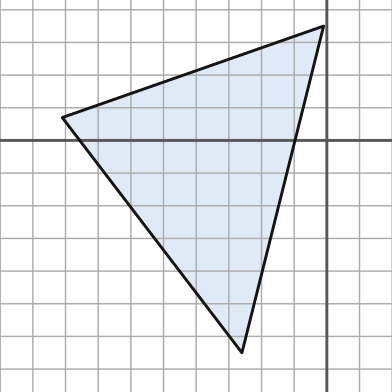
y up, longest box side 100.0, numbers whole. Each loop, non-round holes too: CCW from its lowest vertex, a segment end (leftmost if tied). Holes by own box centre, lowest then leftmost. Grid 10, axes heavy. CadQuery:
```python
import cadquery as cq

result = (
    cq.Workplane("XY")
    .moveTo(-26.0, -65.0)
    .lineTo(-1.0, 35.0)
    .lineTo(-81.0, 7.0)
    .close()
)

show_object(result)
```